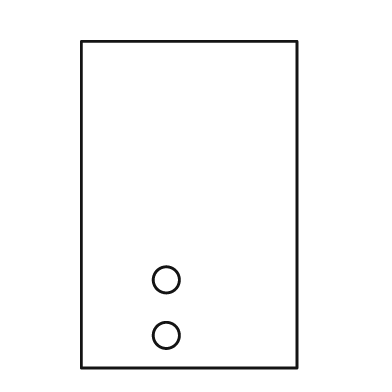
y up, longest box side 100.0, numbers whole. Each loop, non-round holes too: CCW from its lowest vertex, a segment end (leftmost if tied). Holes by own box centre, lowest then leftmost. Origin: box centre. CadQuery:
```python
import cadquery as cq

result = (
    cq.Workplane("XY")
    .moveTo(-33.0, -50.0)
    .lineTo(33.0, -50.0)
    .lineTo(33.0, 50.0)
    .lineTo(-33.0, 50.0)
    .close()
    .moveTo(-7.0, -40.0)
    .circle(4.0)
    .moveTo(-7.0, -23.0)
    .circle(4.0)
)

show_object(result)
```